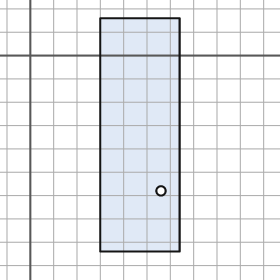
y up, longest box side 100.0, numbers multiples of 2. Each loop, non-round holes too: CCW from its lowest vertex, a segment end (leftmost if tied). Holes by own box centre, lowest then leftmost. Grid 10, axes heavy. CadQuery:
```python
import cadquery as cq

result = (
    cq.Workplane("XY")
    .moveTo(30.0, -84.0)
    .lineTo(64.0, -84.0)
    .lineTo(64.0, 16.0)
    .lineTo(30.0, 16.0)
    .close()
    .moveTo(56.0, -58.0)
    .circle(2.0)
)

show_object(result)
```